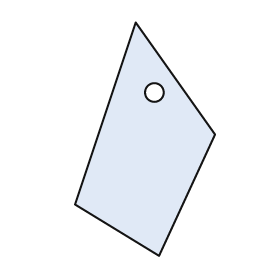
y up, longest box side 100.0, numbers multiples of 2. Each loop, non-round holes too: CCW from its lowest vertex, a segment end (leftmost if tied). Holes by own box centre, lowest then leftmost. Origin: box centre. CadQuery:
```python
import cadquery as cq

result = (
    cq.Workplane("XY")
    .moveTo(6.0, -50.0)
    .lineTo(30.0, 2.0)
    .lineTo(-4.0, 50.0)
    .lineTo(-30.0, -28.0)
    .close()
    .moveTo(4.0, 20.0)
    .circle(4.0)
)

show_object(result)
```